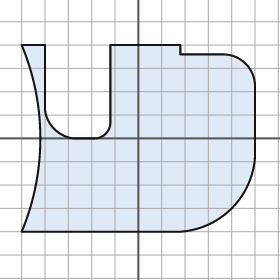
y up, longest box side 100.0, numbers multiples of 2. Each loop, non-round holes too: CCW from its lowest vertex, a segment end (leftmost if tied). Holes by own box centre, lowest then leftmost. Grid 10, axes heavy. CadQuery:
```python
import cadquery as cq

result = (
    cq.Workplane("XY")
    .moveTo(-50.0, -40.0)
    .lineTo(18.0, -40.0)
    .threePointArc((40.0, -30.0), (50.0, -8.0))
    .lineTo(50.0, 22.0)
    .threePointArc((46.0, 32.0), (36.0, 36.0))
    .lineTo(18.0, 36.0)
    .lineTo(18.0, 40.0)
    .lineTo(-12.0, 40.0)
    .lineTo(-12.0, 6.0)
    .threePointArc((-14.0, 2.0), (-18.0, 0.0))
    .lineTo(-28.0, 0.0)
    .threePointArc((-36.0, 4.0), (-40.0, 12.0))
    .lineTo(-40.0, 40.0)
    .lineTo(-50.0, 40.0)
    .threePointArc((-42.0, 0.0), (-50.0, -40.0))
    .close()
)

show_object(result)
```